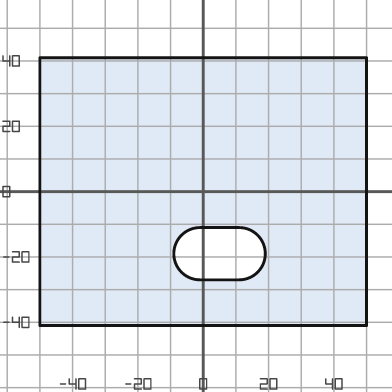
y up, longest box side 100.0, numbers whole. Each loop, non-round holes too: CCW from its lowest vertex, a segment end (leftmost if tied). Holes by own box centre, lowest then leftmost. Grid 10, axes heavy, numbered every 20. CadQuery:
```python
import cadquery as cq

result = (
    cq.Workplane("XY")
    .moveTo(-50.0, -41.0)
    .lineTo(50.0, -41.0)
    .lineTo(50.0, 41.0)
    .lineTo(-50.0, 41.0)
    .close()
    .moveTo(-1.0, -27.0)
    .lineTo(11.0, -27.0)
    .threePointArc((19.0, -19.0), (11.0, -11.0))
    .lineTo(-1.0, -11.0)
    .threePointArc((-9.0, -19.0), (-1.0, -27.0))
    .close()
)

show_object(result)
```